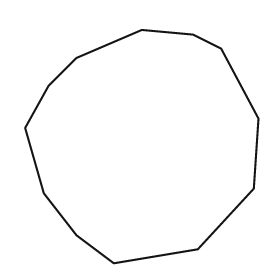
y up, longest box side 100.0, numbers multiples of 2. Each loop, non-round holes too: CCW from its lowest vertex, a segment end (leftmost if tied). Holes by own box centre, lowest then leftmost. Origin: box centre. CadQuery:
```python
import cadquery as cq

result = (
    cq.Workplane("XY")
    .moveTo(-12.0, -50.0)
    .lineTo(24.0, -44.0)
    .lineTo(48.0, -18.0)
    .lineTo(50.0, 12.0)
    .lineTo(34.0, 42.0)
    .lineTo(22.0, 48.0)
    .lineTo(0.0, 50.0)
    .lineTo(-28.0, 38.0)
    .lineTo(-40.0, 26.0)
    .lineTo(-50.0, 8.0)
    .lineTo(-42.0, -20.0)
    .lineTo(-28.0, -38.0)
    .close()
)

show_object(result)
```